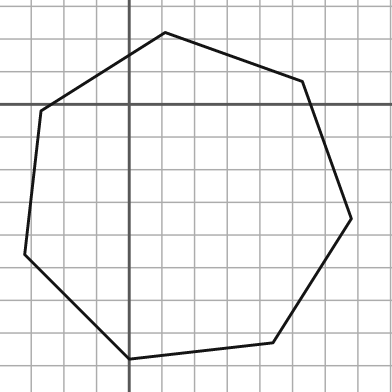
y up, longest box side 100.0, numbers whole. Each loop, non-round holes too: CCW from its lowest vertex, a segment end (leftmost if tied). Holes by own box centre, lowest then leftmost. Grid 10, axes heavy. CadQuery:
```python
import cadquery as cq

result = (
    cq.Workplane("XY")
    .moveTo(0.0, -78.0)
    .lineTo(44.0, -73.0)
    .lineTo(68.0, -35.0)
    .lineTo(53.0, 7.0)
    .lineTo(11.0, 22.0)
    .lineTo(-27.0, -2.0)
    .lineTo(-32.0, -46.0)
    .close()
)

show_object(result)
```